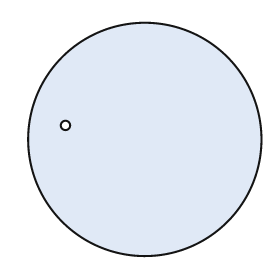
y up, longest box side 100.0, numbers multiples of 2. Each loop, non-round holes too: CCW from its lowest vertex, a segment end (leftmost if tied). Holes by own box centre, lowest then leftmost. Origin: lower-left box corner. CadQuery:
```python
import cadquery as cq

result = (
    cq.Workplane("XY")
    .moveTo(50.0, 50.0)
    .circle(50.0)
    .moveTo(16.0, 56.0)
    .circle(2.0)
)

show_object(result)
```